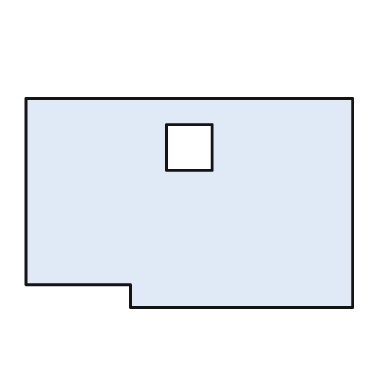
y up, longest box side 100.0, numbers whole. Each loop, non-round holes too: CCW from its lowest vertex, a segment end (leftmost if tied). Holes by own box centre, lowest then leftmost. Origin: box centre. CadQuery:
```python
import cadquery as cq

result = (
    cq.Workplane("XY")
    .moveTo(-18.0, -32.0)
    .lineTo(50.0, -32.0)
    .lineTo(50.0, 32.0)
    .lineTo(-50.0, 32.0)
    .lineTo(-50.0, -25.0)
    .lineTo(-18.0, -25.0)
    .close()
    .moveTo(-7.0, 10.0)
    .lineTo(7.0, 10.0)
    .lineTo(7.0, 24.0)
    .lineTo(-7.0, 24.0)
    .close()
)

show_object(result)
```